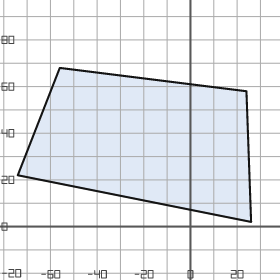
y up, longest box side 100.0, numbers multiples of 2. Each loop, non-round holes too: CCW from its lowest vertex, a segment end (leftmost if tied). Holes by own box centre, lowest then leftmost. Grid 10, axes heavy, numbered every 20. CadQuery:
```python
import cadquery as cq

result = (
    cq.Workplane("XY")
    .moveTo(26.0, 2.0)
    .lineTo(24.0, 58.0)
    .lineTo(-56.0, 68.0)
    .lineTo(-74.0, 22.0)
    .close()
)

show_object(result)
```